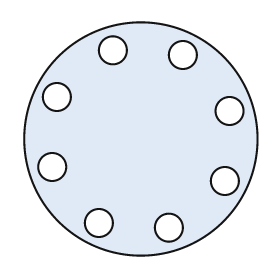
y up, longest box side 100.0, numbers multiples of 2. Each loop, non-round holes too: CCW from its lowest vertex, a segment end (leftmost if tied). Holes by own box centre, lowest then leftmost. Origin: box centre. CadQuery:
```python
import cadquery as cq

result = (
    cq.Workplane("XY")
    .moveTo(0.0, 0.0)
    .circle(50.0)
    .moveTo(12.0, -38.0)
    .circle(6.0)
    .moveTo(-18.0, -36.0)
    .circle(6.0)
    .moveTo(36.0, -18.0)
    .circle(6.0)
    .moveTo(-38.0, -12.0)
    .circle(6.0)
    .moveTo(38.0, 12.0)
    .circle(6.0)
    .moveTo(-36.0, 18.0)
    .circle(6.0)
    .moveTo(18.0, 36.0)
    .circle(6.0)
    .moveTo(-12.0, 38.0)
    .circle(6.0)
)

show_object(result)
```